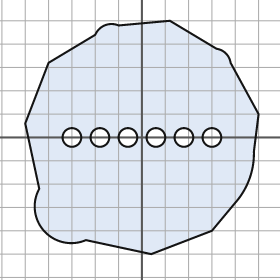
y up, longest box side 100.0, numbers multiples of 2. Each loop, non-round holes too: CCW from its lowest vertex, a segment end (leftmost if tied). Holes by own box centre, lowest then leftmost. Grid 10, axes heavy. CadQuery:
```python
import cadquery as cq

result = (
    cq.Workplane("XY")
    .moveTo(4.0, -50.0)
    .lineTo(30.0, -40.0)
    .lineTo(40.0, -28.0)
    .threePointArc((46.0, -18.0), (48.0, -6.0))
    .lineTo(50.0, 10.0)
    .lineTo(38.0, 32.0)
    .threePointArc((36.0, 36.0), (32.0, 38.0))
    .lineTo(12.0, 50.0)
    .lineTo(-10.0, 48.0)
    .threePointArc((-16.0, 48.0), (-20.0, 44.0))
    .lineTo(-40.0, 32.0)
    .lineTo(-50.0, 6.0)
    .lineTo(-44.0, -22.0)
    .threePointArc((-42.0, -40.0), (-24.0, -44.0))
    .close()
    .moveTo(-30.0, 0.0)
    .circle(4.0)
    .moveTo(-18.0, 0.0)
    .circle(4.0)
    .moveTo(-6.0, 0.0)
    .circle(4.0)
    .moveTo(6.0, 0.0)
    .circle(4.0)
    .moveTo(18.0, 0.0)
    .circle(4.0)
    .moveTo(30.0, 0.0)
    .circle(4.0)
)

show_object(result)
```